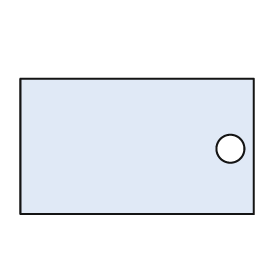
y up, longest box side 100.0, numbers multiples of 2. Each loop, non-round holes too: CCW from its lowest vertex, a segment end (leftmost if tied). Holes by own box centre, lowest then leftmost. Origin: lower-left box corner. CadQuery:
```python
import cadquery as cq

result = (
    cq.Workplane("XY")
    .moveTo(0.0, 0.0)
    .lineTo(100.0, 0.0)
    .lineTo(100.0, 58.0)
    .lineTo(0.0, 58.0)
    .close()
    .moveTo(90.0, 28.0)
    .circle(6.0)
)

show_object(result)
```